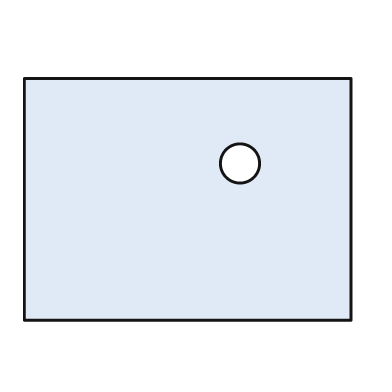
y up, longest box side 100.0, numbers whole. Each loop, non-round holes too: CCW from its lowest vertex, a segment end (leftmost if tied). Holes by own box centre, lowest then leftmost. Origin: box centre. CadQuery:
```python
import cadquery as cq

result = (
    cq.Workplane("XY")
    .moveTo(-50.0, -37.0)
    .lineTo(50.0, -37.0)
    .lineTo(50.0, 37.0)
    .lineTo(-50.0, 37.0)
    .close()
    .moveTo(16.0, 11.0)
    .circle(6.0)
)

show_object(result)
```